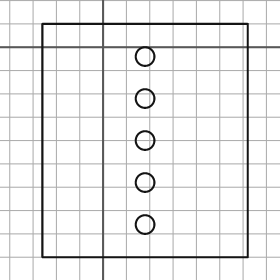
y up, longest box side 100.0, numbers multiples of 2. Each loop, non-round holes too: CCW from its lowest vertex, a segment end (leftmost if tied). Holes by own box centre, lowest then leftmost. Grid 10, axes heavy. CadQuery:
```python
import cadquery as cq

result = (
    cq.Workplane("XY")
    .moveTo(-26.0, -90.0)
    .lineTo(62.0, -90.0)
    .lineTo(62.0, 10.0)
    .lineTo(-26.0, 10.0)
    .close()
    .moveTo(18.0, -76.0)
    .circle(4.0)
    .moveTo(18.0, -58.0)
    .circle(4.0)
    .moveTo(18.0, -40.0)
    .circle(4.0)
    .moveTo(18.0, -22.0)
    .circle(4.0)
    .moveTo(18.0, -4.0)
    .circle(4.0)
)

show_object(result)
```